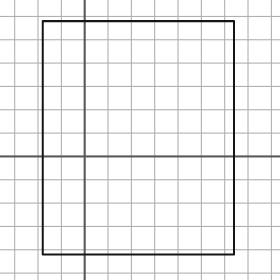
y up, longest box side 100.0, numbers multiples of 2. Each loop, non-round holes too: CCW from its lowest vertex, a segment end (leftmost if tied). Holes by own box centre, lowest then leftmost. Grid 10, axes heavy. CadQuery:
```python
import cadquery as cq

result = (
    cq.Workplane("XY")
    .moveTo(-18.0, -42.0)
    .lineTo(64.0, -42.0)
    .lineTo(64.0, 58.0)
    .lineTo(-18.0, 58.0)
    .close()
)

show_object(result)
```